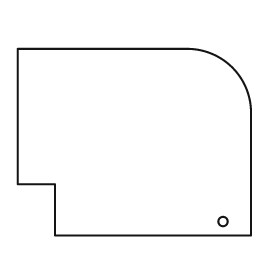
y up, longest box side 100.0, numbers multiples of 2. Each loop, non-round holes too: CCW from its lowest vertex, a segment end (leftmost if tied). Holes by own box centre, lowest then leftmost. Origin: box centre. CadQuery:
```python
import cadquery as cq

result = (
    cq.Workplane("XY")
    .moveTo(-34.0, -40.0)
    .lineTo(50.0, -40.0)
    .lineTo(50.0, 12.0)
    .threePointArc((42.0, 32.0), (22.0, 40.0))
    .lineTo(-50.0, 40.0)
    .lineTo(-50.0, -18.0)
    .lineTo(-34.0, -18.0)
    .close()
    .moveTo(38.0, -34.0)
    .circle(2.0)
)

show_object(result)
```